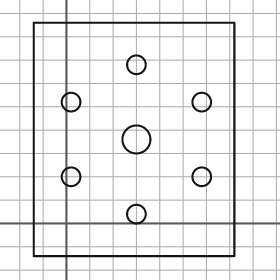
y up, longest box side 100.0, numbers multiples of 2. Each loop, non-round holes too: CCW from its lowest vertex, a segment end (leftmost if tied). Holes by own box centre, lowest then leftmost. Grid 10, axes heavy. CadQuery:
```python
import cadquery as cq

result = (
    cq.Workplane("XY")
    .moveTo(-14.0, -14.0)
    .lineTo(72.0, -14.0)
    .lineTo(72.0, 86.0)
    .lineTo(-14.0, 86.0)
    .close()
    .moveTo(30.0, 4.0)
    .circle(4.0)
    .moveTo(2.0, 20.0)
    .circle(4.0)
    .moveTo(58.0, 20.0)
    .circle(4.0)
    .moveTo(30.0, 36.0)
    .circle(6.0)
    .moveTo(2.0, 52.0)
    .circle(4.0)
    .moveTo(58.0, 52.0)
    .circle(4.0)
    .moveTo(30.0, 68.0)
    .circle(4.0)
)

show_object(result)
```